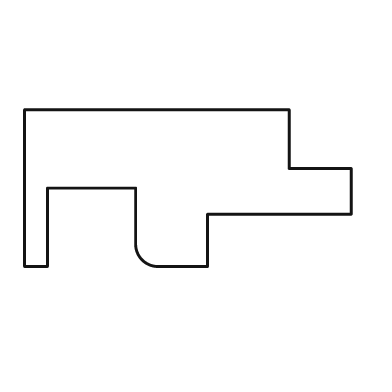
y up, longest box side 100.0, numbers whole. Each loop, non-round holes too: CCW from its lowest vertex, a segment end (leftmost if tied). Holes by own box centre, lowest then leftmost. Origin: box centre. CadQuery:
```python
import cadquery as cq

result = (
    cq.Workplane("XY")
    .moveTo(-50.0, -24.0)
    .lineTo(-43.0, -24.0)
    .lineTo(-43.0, 0.0)
    .lineTo(-16.0, 0.0)
    .lineTo(-16.0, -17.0)
    .threePointArc((-14.0, -22.0), (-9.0, -24.0))
    .lineTo(6.0, -24.0)
    .lineTo(6.0, -8.0)
    .lineTo(50.0, -8.0)
    .lineTo(50.0, 6.0)
    .lineTo(31.0, 6.0)
    .lineTo(31.0, 24.0)
    .lineTo(-50.0, 24.0)
    .close()
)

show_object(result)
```